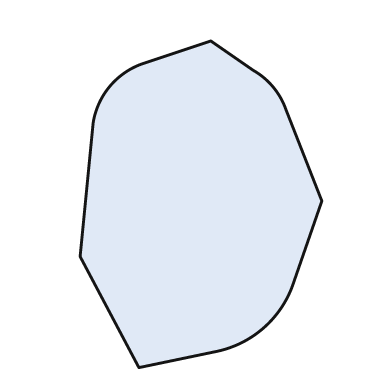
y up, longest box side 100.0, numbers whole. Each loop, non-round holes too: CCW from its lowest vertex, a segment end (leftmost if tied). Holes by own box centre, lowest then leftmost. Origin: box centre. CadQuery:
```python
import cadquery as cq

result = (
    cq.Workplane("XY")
    .moveTo(-19.0, -50.0)
    .lineTo(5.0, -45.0)
    .threePointArc((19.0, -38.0), (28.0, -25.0))
    .lineTo(37.0, 1.0)
    .lineTo(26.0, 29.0)
    .threePointArc((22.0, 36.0), (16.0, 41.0))
    .lineTo(3.0, 50.0)
    .lineTo(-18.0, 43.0)
    .threePointArc((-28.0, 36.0), (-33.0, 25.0))
    .lineTo(-37.0, -16.0)
    .close()
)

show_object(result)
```